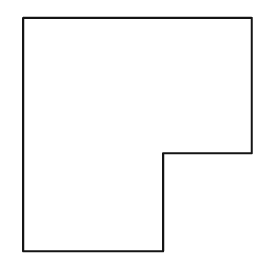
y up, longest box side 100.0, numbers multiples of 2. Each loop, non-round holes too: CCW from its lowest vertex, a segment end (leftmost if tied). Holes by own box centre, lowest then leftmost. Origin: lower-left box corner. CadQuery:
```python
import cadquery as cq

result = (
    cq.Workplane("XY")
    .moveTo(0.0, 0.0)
    .lineTo(60.0, 0.0)
    .lineTo(60.0, 42.0)
    .lineTo(98.0, 42.0)
    .lineTo(98.0, 100.0)
    .lineTo(0.0, 100.0)
    .close()
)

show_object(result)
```